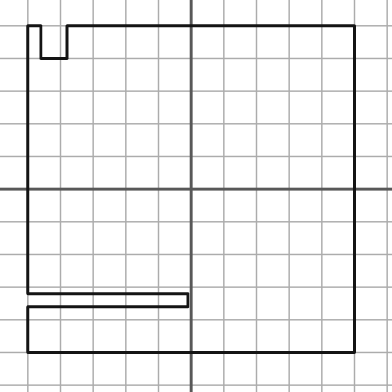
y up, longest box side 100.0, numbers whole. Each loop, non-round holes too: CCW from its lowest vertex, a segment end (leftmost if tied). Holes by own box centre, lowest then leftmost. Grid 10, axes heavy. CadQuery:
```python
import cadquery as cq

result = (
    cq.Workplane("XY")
    .moveTo(-50.0, -50.0)
    .lineTo(50.0, -50.0)
    .lineTo(50.0, 50.0)
    .lineTo(-38.0, 50.0)
    .lineTo(-38.0, 40.0)
    .lineTo(-46.0, 40.0)
    .lineTo(-46.0, 50.0)
    .lineTo(-50.0, 50.0)
    .lineTo(-50.0, -32.0)
    .lineTo(-1.0, -32.0)
    .lineTo(-1.0, -36.0)
    .lineTo(-50.0, -36.0)
    .close()
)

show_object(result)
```